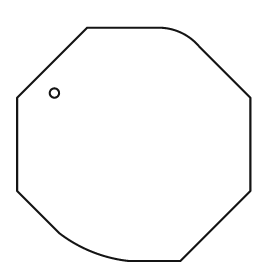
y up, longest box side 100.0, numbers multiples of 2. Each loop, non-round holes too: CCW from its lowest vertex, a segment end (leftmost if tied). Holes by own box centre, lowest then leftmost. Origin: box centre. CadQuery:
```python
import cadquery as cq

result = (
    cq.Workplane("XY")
    .moveTo(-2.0, -50.0)
    .lineTo(20.0, -50.0)
    .lineTo(50.0, -20.0)
    .lineTo(50.0, 20.0)
    .lineTo(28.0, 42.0)
    .threePointArc((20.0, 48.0), (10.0, 50.0))
    .lineTo(-20.0, 50.0)
    .lineTo(-50.0, 20.0)
    .lineTo(-50.0, -20.0)
    .lineTo(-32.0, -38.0)
    .threePointArc((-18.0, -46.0), (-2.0, -50.0))
    .close()
    .moveTo(-34.0, 22.0)
    .circle(2.0)
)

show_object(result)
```